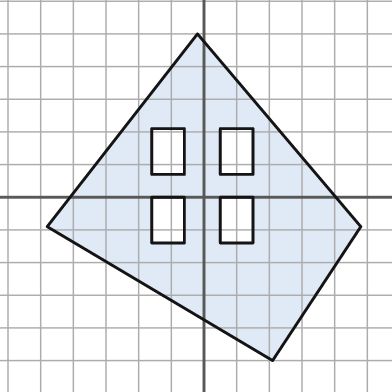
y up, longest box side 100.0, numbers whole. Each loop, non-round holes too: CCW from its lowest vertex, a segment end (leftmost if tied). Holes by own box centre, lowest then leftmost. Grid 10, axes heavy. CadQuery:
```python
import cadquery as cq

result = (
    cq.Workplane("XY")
    .moveTo(21.0, -50.0)
    .lineTo(48.0, -9.0)
    .lineTo(-2.0, 50.0)
    .lineTo(-48.0, -9.0)
    .close()
    .moveTo(-16.0, -14.0)
    .lineTo(-6.0, -14.0)
    .lineTo(-6.0, 0.0)
    .lineTo(-16.0, 0.0)
    .close()
    .moveTo(5.0, -14.0)
    .lineTo(15.0, -14.0)
    .lineTo(15.0, 0.0)
    .lineTo(5.0, 0.0)
    .close()
    .moveTo(-16.0, 7.0)
    .lineTo(-6.0, 7.0)
    .lineTo(-6.0, 21.0)
    .lineTo(-16.0, 21.0)
    .close()
    .moveTo(5.0, 7.0)
    .lineTo(15.0, 7.0)
    .lineTo(15.0, 21.0)
    .lineTo(5.0, 21.0)
    .close()
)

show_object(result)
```